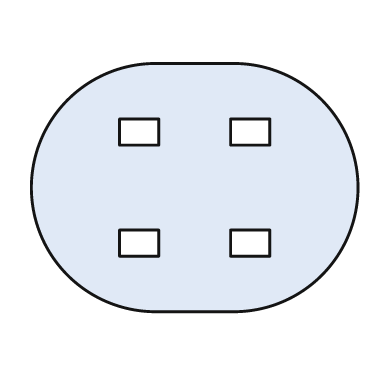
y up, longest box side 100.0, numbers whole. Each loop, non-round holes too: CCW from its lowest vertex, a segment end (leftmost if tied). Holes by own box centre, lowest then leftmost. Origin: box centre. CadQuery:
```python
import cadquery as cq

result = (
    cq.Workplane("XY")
    .moveTo(-12.0, -38.0)
    .lineTo(12.0, -38.0)
    .threePointArc((50.0, 0.0), (12.0, 38.0))
    .lineTo(-12.0, 38.0)
    .threePointArc((-50.0, 0.0), (-12.0, -38.0))
    .close()
    .moveTo(-23.0, -21.0)
    .lineTo(-11.0, -21.0)
    .lineTo(-11.0, -13.0)
    .lineTo(-23.0, -13.0)
    .close()
    .moveTo(11.0, -21.0)
    .lineTo(23.0, -21.0)
    .lineTo(23.0, -13.0)
    .lineTo(11.0, -13.0)
    .close()
    .moveTo(-23.0, 13.0)
    .lineTo(-11.0, 13.0)
    .lineTo(-11.0, 21.0)
    .lineTo(-23.0, 21.0)
    .close()
    .moveTo(11.0, 13.0)
    .lineTo(23.0, 13.0)
    .lineTo(23.0, 21.0)
    .lineTo(11.0, 21.0)
    .close()
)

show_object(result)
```